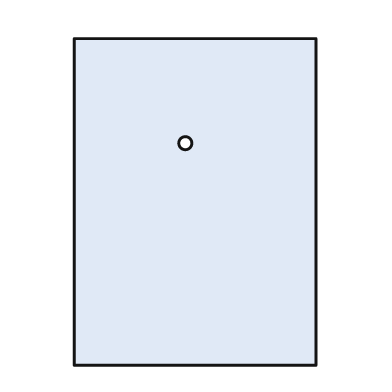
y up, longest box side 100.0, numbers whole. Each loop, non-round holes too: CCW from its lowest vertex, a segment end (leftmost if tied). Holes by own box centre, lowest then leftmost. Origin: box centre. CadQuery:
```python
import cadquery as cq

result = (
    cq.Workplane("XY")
    .moveTo(-37.0, -50.0)
    .lineTo(37.0, -50.0)
    .lineTo(37.0, 50.0)
    .lineTo(-37.0, 50.0)
    .close()
    .moveTo(-3.0, 18.0)
    .circle(2.0)
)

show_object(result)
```